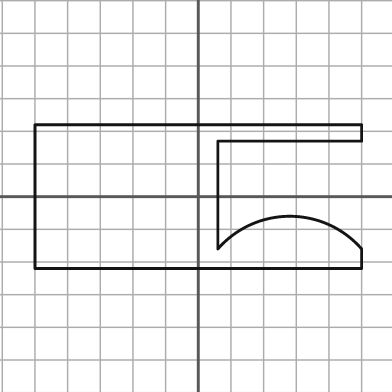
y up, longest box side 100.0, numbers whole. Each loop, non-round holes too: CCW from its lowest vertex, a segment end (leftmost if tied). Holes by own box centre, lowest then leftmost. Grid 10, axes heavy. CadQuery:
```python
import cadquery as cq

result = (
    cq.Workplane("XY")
    .moveTo(-50.0, -22.0)
    .lineTo(50.0, -22.0)
    .lineTo(50.0, -16.0)
    .threePointArc((28.0, -6.0), (6.0, -16.0))
    .lineTo(6.0, 17.0)
    .lineTo(50.0, 17.0)
    .lineTo(50.0, 22.0)
    .lineTo(-50.0, 22.0)
    .close()
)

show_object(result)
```